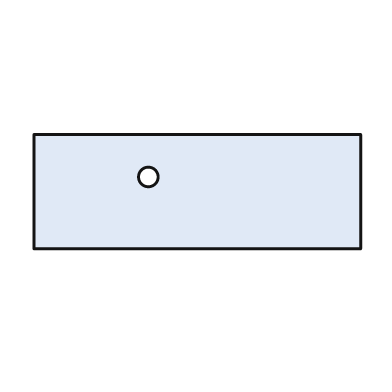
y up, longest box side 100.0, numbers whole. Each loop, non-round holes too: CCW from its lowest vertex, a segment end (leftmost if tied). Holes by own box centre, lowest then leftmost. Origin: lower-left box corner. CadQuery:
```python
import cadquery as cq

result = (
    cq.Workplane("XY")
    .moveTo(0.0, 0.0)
    .lineTo(100.0, 0.0)
    .lineTo(100.0, 35.0)
    .lineTo(0.0, 35.0)
    .close()
    .moveTo(35.0, 22.0)
    .circle(3.0)
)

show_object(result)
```